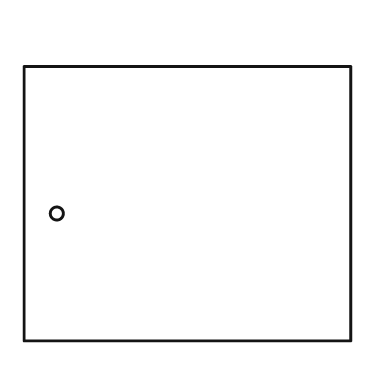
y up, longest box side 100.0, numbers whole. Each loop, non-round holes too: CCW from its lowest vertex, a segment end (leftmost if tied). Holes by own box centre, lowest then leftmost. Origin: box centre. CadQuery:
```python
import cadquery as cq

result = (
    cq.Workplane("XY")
    .moveTo(-50.0, -42.0)
    .lineTo(50.0, -42.0)
    .lineTo(50.0, 42.0)
    .lineTo(-50.0, 42.0)
    .close()
    .moveTo(-40.0, -3.0)
    .circle(2.0)
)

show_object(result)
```